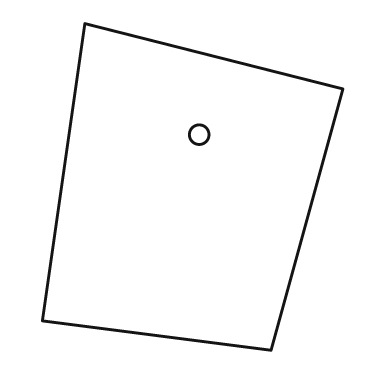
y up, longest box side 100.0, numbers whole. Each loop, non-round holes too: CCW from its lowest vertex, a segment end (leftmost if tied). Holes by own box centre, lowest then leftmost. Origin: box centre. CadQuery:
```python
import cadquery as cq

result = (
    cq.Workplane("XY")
    .moveTo(24.0, -50.0)
    .lineTo(46.0, 30.0)
    .lineTo(-33.0, 50.0)
    .lineTo(-46.0, -41.0)
    .close()
    .moveTo(2.0, 16.0)
    .circle(3.0)
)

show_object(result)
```